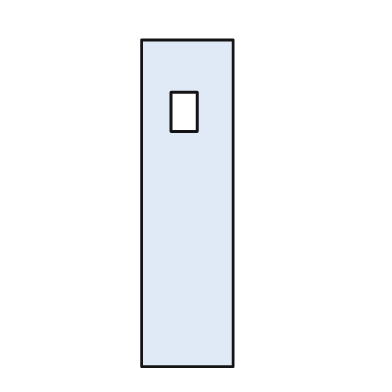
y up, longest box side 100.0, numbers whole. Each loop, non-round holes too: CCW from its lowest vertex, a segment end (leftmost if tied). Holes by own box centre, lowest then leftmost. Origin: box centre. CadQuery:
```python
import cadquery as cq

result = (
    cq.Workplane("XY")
    .moveTo(-14.0, -50.0)
    .lineTo(14.0, -50.0)
    .lineTo(14.0, 50.0)
    .lineTo(-14.0, 50.0)
    .close()
    .moveTo(-5.0, 22.0)
    .lineTo(3.0, 22.0)
    .lineTo(3.0, 34.0)
    .lineTo(-5.0, 34.0)
    .close()
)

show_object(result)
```